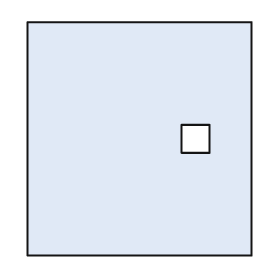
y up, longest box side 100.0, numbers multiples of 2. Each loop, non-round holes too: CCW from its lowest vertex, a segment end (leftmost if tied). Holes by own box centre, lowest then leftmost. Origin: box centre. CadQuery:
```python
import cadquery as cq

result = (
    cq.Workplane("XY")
    .moveTo(-48.0, -50.0)
    .lineTo(48.0, -50.0)
    .lineTo(48.0, 50.0)
    .lineTo(-48.0, 50.0)
    .close()
    .moveTo(18.0, -6.0)
    .lineTo(30.0, -6.0)
    .lineTo(30.0, 6.0)
    .lineTo(18.0, 6.0)
    .close()
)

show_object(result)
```